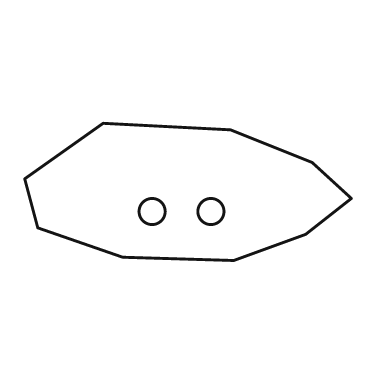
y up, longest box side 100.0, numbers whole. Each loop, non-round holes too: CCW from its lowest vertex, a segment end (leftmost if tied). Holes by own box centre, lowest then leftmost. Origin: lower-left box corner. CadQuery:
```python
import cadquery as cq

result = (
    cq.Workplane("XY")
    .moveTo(64.0, 0.0)
    .lineTo(86.0, 8.0)
    .lineTo(100.0, 19.0)
    .lineTo(88.0, 30.0)
    .lineTo(63.0, 40.0)
    .lineTo(24.0, 42.0)
    .lineTo(0.0, 25.0)
    .lineTo(4.0, 10.0)
    .lineTo(30.0, 1.0)
    .close()
    .moveTo(39.0, 15.0)
    .circle(4.0)
    .moveTo(57.0, 15.0)
    .circle(4.0)
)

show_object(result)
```